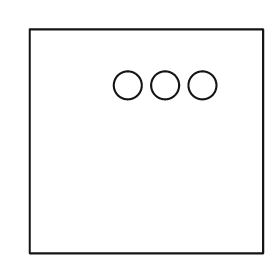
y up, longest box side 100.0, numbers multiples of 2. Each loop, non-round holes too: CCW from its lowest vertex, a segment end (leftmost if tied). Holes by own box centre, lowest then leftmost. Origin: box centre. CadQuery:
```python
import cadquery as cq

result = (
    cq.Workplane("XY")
    .moveTo(-50.0, -48.0)
    .lineTo(50.0, -48.0)
    .lineTo(50.0, 48.0)
    .lineTo(-50.0, 48.0)
    .close()
    .moveTo(-8.0, 24.0)
    .circle(6.0)
    .moveTo(8.0, 24.0)
    .circle(6.0)
    .moveTo(24.0, 24.0)
    .circle(6.0)
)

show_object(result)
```